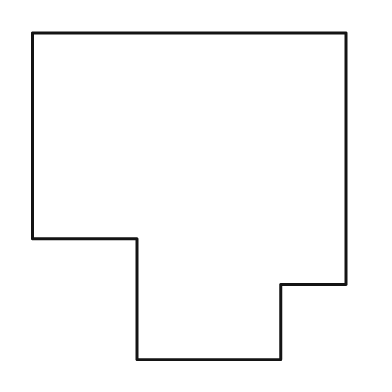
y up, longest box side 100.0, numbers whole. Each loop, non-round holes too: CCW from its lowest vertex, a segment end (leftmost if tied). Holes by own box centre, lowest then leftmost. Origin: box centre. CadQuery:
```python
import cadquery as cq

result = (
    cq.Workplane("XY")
    .moveTo(-16.0, -50.0)
    .lineTo(28.0, -50.0)
    .lineTo(28.0, -27.0)
    .lineTo(48.0, -27.0)
    .lineTo(48.0, 50.0)
    .lineTo(-48.0, 50.0)
    .lineTo(-48.0, -13.0)
    .lineTo(-16.0, -13.0)
    .close()
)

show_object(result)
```